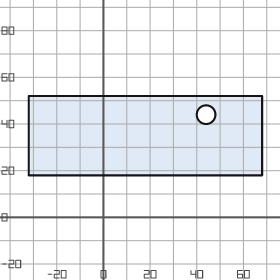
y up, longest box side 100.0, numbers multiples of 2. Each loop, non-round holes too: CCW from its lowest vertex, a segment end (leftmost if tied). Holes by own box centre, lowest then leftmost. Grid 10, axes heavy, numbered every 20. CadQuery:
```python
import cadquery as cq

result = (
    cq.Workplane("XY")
    .moveTo(-32.0, 18.0)
    .lineTo(68.0, 18.0)
    .lineTo(68.0, 52.0)
    .lineTo(-32.0, 52.0)
    .close()
    .moveTo(44.0, 44.0)
    .circle(4.0)
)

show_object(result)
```